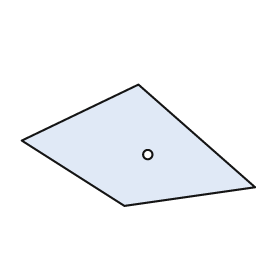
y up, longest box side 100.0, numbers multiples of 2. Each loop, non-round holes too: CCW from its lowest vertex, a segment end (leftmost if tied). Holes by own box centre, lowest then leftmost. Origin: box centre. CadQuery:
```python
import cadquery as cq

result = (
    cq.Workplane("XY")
    .moveTo(-6.0, -26.0)
    .lineTo(50.0, -18.0)
    .lineTo(0.0, 26.0)
    .lineTo(-50.0, 2.0)
    .close()
    .moveTo(4.0, -4.0)
    .circle(2.0)
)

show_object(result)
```